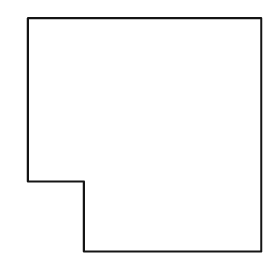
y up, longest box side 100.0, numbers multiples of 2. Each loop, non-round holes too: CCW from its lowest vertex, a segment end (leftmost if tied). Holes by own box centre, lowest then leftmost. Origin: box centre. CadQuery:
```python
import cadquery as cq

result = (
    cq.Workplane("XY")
    .moveTo(-26.0, -50.0)
    .lineTo(50.0, -50.0)
    .lineTo(50.0, 50.0)
    .lineTo(-50.0, 50.0)
    .lineTo(-50.0, -20.0)
    .lineTo(-26.0, -20.0)
    .close()
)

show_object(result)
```